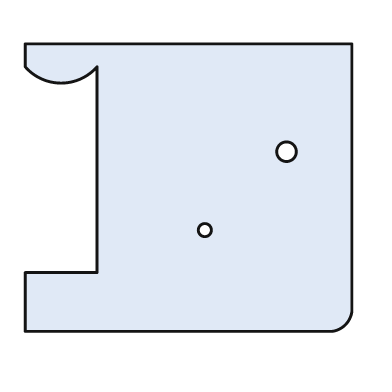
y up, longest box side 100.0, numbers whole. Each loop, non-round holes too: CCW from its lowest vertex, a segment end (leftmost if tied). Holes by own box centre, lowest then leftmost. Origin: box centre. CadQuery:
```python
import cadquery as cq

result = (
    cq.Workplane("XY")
    .moveTo(-50.0, -44.0)
    .lineTo(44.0, -44.0)
    .threePointArc((48.0, -42.0), (50.0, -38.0))
    .lineTo(50.0, 44.0)
    .lineTo(-50.0, 44.0)
    .lineTo(-50.0, 37.0)
    .threePointArc((-39.0, 32.0), (-28.0, 37.0))
    .lineTo(-28.0, -26.0)
    .lineTo(-50.0, -26.0)
    .close()
    .moveTo(5.0, -13.0)
    .circle(2.0)
    .moveTo(30.0, 11.0)
    .circle(3.0)
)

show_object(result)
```